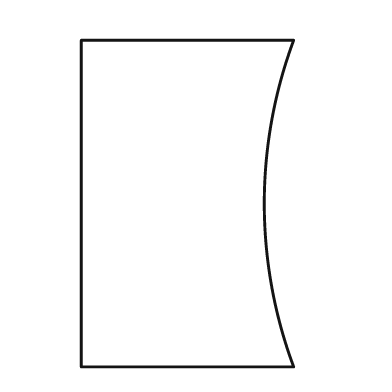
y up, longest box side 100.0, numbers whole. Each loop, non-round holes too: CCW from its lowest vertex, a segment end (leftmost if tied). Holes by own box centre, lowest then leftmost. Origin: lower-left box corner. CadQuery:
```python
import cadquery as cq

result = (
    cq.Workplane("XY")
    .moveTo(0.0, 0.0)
    .lineTo(65.0, 0.0)
    .threePointArc((56.0, 50.0), (65.0, 100.0))
    .lineTo(0.0, 100.0)
    .close()
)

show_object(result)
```